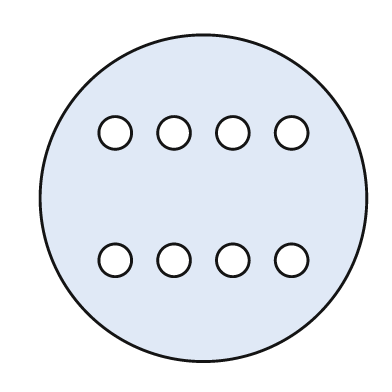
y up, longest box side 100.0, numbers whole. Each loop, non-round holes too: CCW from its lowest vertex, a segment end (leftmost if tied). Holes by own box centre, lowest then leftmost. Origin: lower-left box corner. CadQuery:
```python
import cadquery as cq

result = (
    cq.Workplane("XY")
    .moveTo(50.0, 50.0)
    .circle(50.0)
    .moveTo(23.0, 31.0)
    .circle(5.0)
    .moveTo(41.0, 31.0)
    .circle(5.0)
    .moveTo(59.0, 31.0)
    .circle(5.0)
    .moveTo(77.0, 31.0)
    .circle(5.0)
    .moveTo(23.0, 70.0)
    .circle(5.0)
    .moveTo(41.0, 70.0)
    .circle(5.0)
    .moveTo(59.0, 70.0)
    .circle(5.0)
    .moveTo(77.0, 70.0)
    .circle(5.0)
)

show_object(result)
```